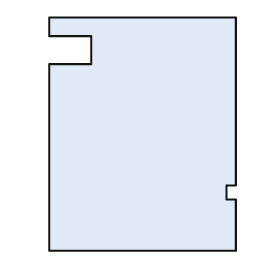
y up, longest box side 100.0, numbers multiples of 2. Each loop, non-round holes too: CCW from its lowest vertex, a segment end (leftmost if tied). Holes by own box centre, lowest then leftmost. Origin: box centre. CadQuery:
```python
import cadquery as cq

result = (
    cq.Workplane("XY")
    .moveTo(-40.0, -50.0)
    .lineTo(40.0, -50.0)
    .lineTo(40.0, -28.0)
    .lineTo(36.0, -28.0)
    .lineTo(36.0, -22.0)
    .lineTo(40.0, -22.0)
    .lineTo(40.0, 50.0)
    .lineTo(-40.0, 50.0)
    .lineTo(-40.0, 42.0)
    .lineTo(-22.0, 42.0)
    .lineTo(-22.0, 30.0)
    .lineTo(-40.0, 30.0)
    .close()
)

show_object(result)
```